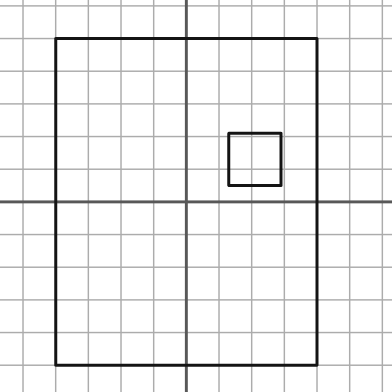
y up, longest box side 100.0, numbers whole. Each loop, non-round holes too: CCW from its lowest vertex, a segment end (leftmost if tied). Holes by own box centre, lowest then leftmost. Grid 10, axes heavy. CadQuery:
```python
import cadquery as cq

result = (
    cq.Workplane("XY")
    .moveTo(-40.0, -50.0)
    .lineTo(40.0, -50.0)
    .lineTo(40.0, 50.0)
    .lineTo(-40.0, 50.0)
    .close()
    .moveTo(13.0, 5.0)
    .lineTo(29.0, 5.0)
    .lineTo(29.0, 21.0)
    .lineTo(13.0, 21.0)
    .close()
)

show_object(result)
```